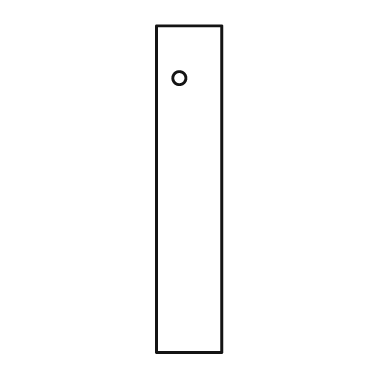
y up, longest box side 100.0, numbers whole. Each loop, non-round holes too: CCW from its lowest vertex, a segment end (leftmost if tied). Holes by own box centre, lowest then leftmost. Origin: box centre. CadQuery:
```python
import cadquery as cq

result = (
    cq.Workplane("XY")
    .moveTo(-10.0, -50.0)
    .lineTo(10.0, -50.0)
    .lineTo(10.0, 50.0)
    .lineTo(-10.0, 50.0)
    .close()
    .moveTo(-3.0, 34.0)
    .circle(2.0)
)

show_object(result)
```